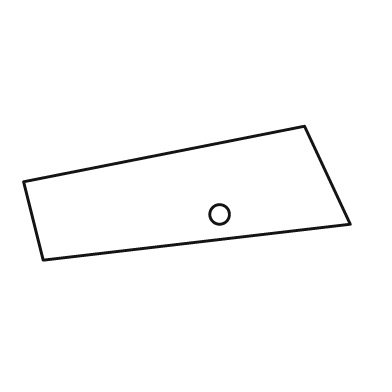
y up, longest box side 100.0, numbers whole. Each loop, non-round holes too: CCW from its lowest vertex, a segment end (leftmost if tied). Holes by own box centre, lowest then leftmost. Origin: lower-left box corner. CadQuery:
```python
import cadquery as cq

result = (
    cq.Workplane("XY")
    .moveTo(6.0, 0.0)
    .lineTo(100.0, 11.0)
    .lineTo(86.0, 41.0)
    .lineTo(0.0, 24.0)
    .close()
    .moveTo(60.0, 14.0)
    .circle(3.0)
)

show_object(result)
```